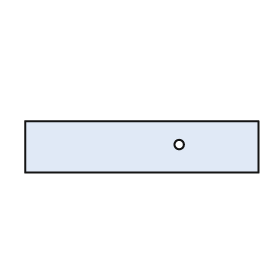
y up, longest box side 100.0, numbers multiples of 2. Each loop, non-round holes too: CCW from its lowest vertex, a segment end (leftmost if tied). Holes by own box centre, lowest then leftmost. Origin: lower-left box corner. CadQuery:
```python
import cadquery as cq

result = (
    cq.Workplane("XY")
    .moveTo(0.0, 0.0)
    .lineTo(100.0, 0.0)
    .lineTo(100.0, 22.0)
    .lineTo(0.0, 22.0)
    .close()
    .moveTo(66.0, 12.0)
    .circle(2.0)
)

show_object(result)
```